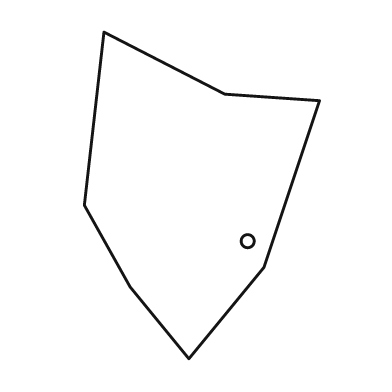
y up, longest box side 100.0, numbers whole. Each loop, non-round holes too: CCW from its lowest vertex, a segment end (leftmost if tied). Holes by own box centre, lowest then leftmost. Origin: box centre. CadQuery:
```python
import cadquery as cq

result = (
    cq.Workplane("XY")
    .moveTo(-4.0, -50.0)
    .lineTo(19.0, -22.0)
    .lineTo(36.0, 29.0)
    .lineTo(7.0, 31.0)
    .lineTo(-30.0, 50.0)
    .lineTo(-36.0, -3.0)
    .lineTo(-22.0, -28.0)
    .close()
    .moveTo(14.0, -14.0)
    .circle(2.0)
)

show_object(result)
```